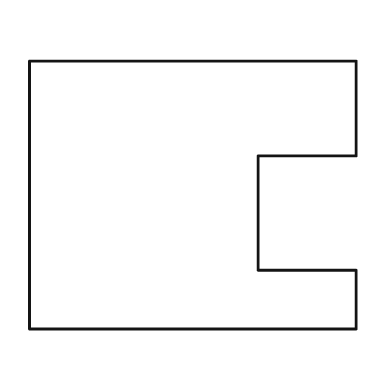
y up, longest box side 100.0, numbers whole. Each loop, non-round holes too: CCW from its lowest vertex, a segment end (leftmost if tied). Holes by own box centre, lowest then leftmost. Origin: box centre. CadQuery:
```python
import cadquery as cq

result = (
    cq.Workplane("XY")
    .moveTo(-50.0, -41.0)
    .lineTo(50.0, -41.0)
    .lineTo(50.0, -23.0)
    .lineTo(20.0, -23.0)
    .lineTo(20.0, 12.0)
    .lineTo(50.0, 12.0)
    .lineTo(50.0, 41.0)
    .lineTo(-50.0, 41.0)
    .close()
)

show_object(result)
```